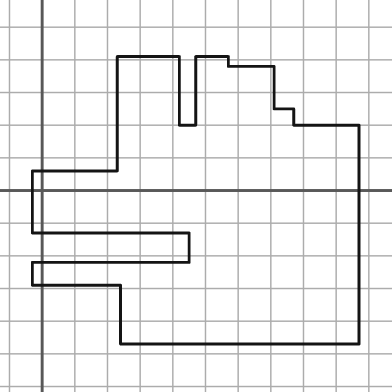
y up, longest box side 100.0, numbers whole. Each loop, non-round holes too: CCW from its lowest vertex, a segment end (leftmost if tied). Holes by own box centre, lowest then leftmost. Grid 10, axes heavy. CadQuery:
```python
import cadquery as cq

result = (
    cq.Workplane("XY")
    .moveTo(24.0, -47.0)
    .lineTo(97.0, -47.0)
    .lineTo(97.0, 20.0)
    .lineTo(77.0, 20.0)
    .lineTo(77.0, 25.0)
    .lineTo(71.0, 25.0)
    .lineTo(71.0, 38.0)
    .lineTo(57.0, 38.0)
    .lineTo(57.0, 41.0)
    .lineTo(47.0, 41.0)
    .lineTo(47.0, 20.0)
    .lineTo(42.0, 20.0)
    .lineTo(42.0, 41.0)
    .lineTo(23.0, 41.0)
    .lineTo(23.0, 6.0)
    .lineTo(-3.0, 6.0)
    .lineTo(-3.0, -13.0)
    .lineTo(45.0, -13.0)
    .lineTo(45.0, -22.0)
    .lineTo(-3.0, -22.0)
    .lineTo(-3.0, -29.0)
    .lineTo(24.0, -29.0)
    .close()
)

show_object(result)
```